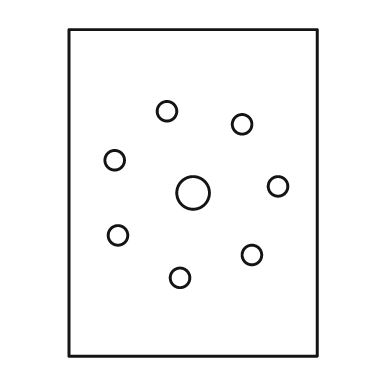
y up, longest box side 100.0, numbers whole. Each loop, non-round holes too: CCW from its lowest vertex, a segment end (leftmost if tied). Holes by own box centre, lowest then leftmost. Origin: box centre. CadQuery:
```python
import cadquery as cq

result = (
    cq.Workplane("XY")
    .moveTo(-38.0, -50.0)
    .lineTo(38.0, -50.0)
    .lineTo(38.0, 50.0)
    .lineTo(-38.0, 50.0)
    .close()
    .moveTo(-4.0, -26.0)
    .circle(3.0)
    .moveTo(18.0, -19.0)
    .circle(3.0)
    .moveTo(-23.0, -13.0)
    .circle(3.0)
    .moveTo(0.0, 0.0)
    .circle(5.0)
    .moveTo(26.0, 2.0)
    .circle(3.0)
    .moveTo(-24.0, 10.0)
    .circle(3.0)
    .moveTo(15.0, 21.0)
    .circle(3.0)
    .moveTo(-8.0, 25.0)
    .circle(3.0)
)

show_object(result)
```